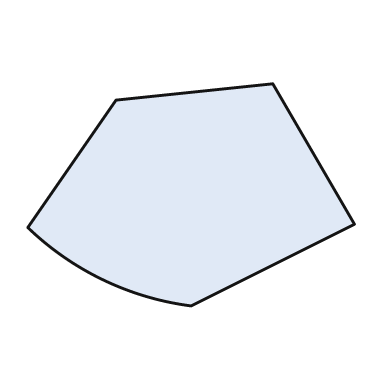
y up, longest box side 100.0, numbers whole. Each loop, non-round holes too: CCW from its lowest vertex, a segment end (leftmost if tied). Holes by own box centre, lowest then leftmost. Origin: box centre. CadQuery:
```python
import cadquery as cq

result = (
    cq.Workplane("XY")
    .moveTo(0.0, -34.0)
    .lineTo(50.0, -9.0)
    .lineTo(25.0, 34.0)
    .lineTo(-23.0, 29.0)
    .lineTo(-50.0, -10.0)
    .threePointArc((-27.0, -26.0), (0.0, -34.0))
    .close()
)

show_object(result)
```